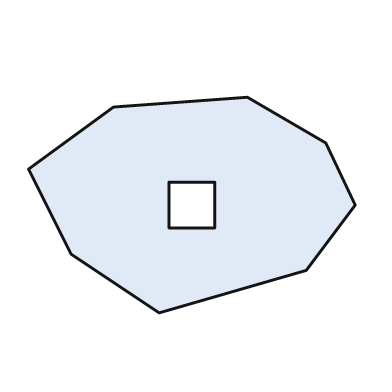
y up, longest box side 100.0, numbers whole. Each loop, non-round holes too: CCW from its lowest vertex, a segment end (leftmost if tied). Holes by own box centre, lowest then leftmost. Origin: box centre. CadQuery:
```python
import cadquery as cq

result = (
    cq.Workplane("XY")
    .moveTo(-10.0, -33.0)
    .lineTo(35.0, -20.0)
    .lineTo(50.0, 0.0)
    .lineTo(41.0, 19.0)
    .lineTo(17.0, 33.0)
    .lineTo(-24.0, 30.0)
    .lineTo(-50.0, 11.0)
    .lineTo(-37.0, -15.0)
    .close()
    .moveTo(-7.0, -7.0)
    .lineTo(7.0, -7.0)
    .lineTo(7.0, 7.0)
    .lineTo(-7.0, 7.0)
    .close()
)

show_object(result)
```